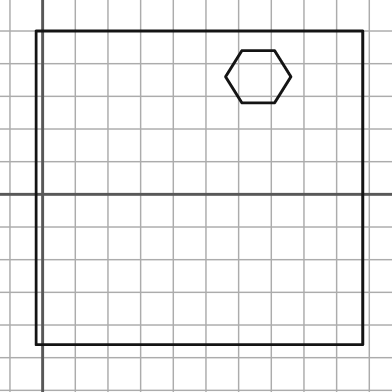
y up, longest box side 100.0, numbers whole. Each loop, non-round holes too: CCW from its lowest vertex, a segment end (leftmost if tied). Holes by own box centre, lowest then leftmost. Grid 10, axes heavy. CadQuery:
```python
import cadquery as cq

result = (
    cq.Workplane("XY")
    .moveTo(-2.0, -46.0)
    .lineTo(98.0, -46.0)
    .lineTo(98.0, 50.0)
    .lineTo(-2.0, 50.0)
    .close()
    .moveTo(61.0, 28.0)
    .lineTo(71.0, 28.0)
    .lineTo(76.0, 36.0)
    .lineTo(71.0, 44.0)
    .lineTo(61.0, 44.0)
    .lineTo(56.0, 36.0)
    .close()
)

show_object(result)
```